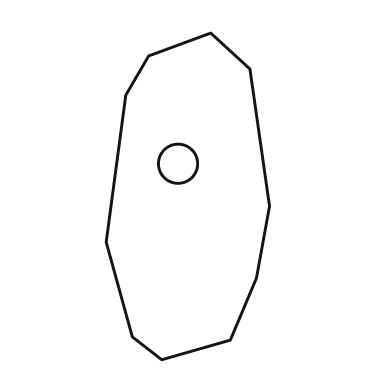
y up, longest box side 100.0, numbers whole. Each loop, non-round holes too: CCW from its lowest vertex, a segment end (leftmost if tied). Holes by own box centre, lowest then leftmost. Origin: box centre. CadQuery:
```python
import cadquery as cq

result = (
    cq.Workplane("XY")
    .moveTo(-8.0, -50.0)
    .lineTo(13.0, -44.0)
    .lineTo(21.0, -25.0)
    .lineTo(25.0, -3.0)
    .lineTo(19.0, 39.0)
    .lineTo(7.0, 50.0)
    .lineTo(-12.0, 43.0)
    .lineTo(-19.0, 31.0)
    .lineTo(-25.0, -14.0)
    .lineTo(-17.0, -43.0)
    .close()
    .moveTo(-3.0, 10.0)
    .circle(6.0)
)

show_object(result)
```